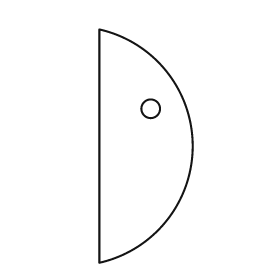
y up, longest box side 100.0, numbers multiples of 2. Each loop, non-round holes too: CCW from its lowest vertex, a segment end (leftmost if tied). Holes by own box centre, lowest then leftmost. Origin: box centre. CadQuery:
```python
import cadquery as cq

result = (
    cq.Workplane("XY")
    .moveTo(-20.0, -50.0)
    .threePointArc((20.0, 0.0), (-20.0, 50.0))
    .close()
    .moveTo(2.0, 16.0)
    .circle(4.0)
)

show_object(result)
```